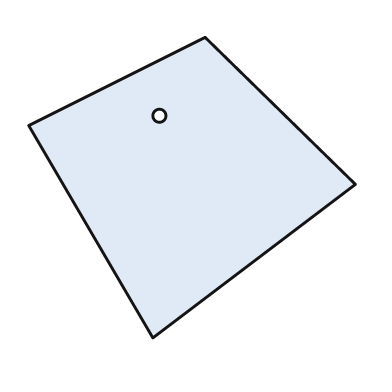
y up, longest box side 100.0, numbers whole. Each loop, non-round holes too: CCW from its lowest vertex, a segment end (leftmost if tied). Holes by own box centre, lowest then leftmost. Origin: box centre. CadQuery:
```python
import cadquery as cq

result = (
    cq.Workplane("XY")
    .moveTo(-12.0, -46.0)
    .lineTo(50.0, 1.0)
    .lineTo(4.0, 46.0)
    .lineTo(-50.0, 19.0)
    .close()
    .moveTo(-10.0, 22.0)
    .circle(2.0)
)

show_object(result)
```